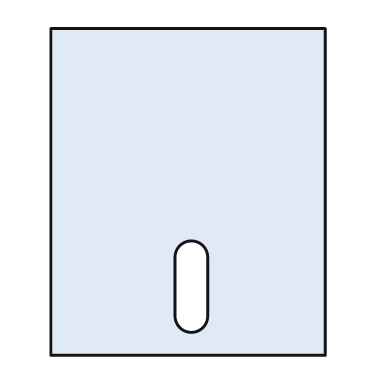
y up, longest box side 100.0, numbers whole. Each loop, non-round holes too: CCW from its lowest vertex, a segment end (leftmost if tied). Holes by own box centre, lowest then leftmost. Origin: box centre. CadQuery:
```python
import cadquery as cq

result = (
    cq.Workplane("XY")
    .moveTo(-42.0, -50.0)
    .lineTo(42.0, -50.0)
    .lineTo(42.0, 50.0)
    .lineTo(-42.0, 50.0)
    .close()
    .moveTo(-4.0, -38.0)
    .threePointArc((1.0, -43.0), (6.0, -38.0))
    .lineTo(6.0, -20.0)
    .threePointArc((1.0, -15.0), (-4.0, -20.0))
    .close()
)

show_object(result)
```